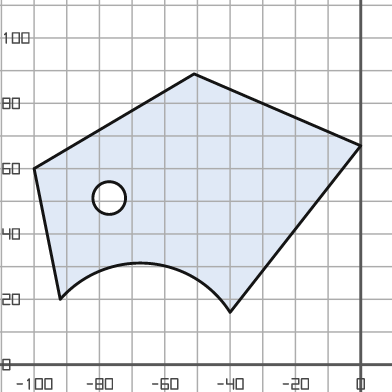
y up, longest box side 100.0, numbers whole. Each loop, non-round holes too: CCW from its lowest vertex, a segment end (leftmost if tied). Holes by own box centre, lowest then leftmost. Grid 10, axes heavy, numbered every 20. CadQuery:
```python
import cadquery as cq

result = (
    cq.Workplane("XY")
    .moveTo(-40.0, 16.0)
    .lineTo(0.0, 67.0)
    .lineTo(-51.0, 89.0)
    .lineTo(-100.0, 60.0)
    .lineTo(-92.0, 20.0)
    .threePointArc((-65.0, 31.0), (-40.0, 16.0))
    .close()
    .moveTo(-77.0, 51.0)
    .circle(5.0)
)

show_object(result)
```